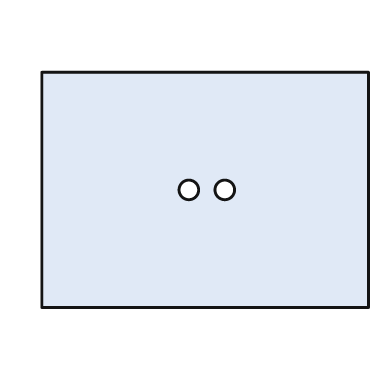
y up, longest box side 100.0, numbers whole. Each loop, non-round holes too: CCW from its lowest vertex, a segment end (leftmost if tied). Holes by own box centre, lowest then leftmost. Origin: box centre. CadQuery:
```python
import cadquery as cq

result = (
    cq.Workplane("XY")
    .moveTo(-50.0, -36.0)
    .lineTo(50.0, -36.0)
    .lineTo(50.0, 36.0)
    .lineTo(-50.0, 36.0)
    .close()
    .moveTo(-5.0, 0.0)
    .circle(3.0)
    .moveTo(6.0, 0.0)
    .circle(3.0)
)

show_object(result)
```